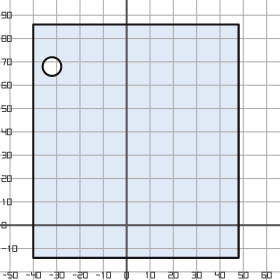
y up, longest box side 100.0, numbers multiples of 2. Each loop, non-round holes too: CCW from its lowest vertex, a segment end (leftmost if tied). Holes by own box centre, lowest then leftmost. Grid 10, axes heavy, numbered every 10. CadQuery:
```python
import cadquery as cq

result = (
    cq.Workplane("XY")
    .moveTo(-40.0, -14.0)
    .lineTo(48.0, -14.0)
    .lineTo(48.0, 86.0)
    .lineTo(-40.0, 86.0)
    .close()
    .moveTo(-32.0, 68.0)
    .circle(4.0)
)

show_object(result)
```